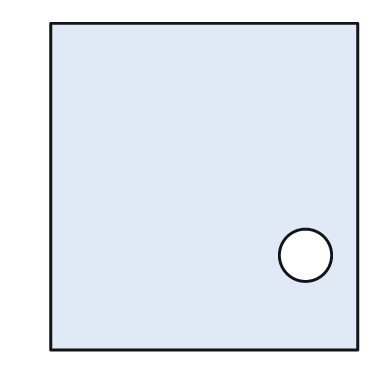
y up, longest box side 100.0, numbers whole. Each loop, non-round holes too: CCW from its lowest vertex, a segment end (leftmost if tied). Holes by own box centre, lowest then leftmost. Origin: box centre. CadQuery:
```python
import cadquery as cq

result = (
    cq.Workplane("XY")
    .moveTo(-47.0, -50.0)
    .lineTo(47.0, -50.0)
    .lineTo(47.0, 50.0)
    .lineTo(-47.0, 50.0)
    .close()
    .moveTo(31.0, -21.0)
    .circle(8.0)
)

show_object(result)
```